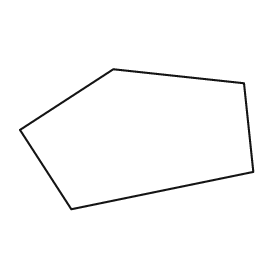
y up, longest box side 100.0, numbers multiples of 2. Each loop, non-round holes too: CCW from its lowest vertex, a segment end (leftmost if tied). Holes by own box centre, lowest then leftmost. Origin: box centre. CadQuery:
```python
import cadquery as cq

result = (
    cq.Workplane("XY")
    .moveTo(-28.0, -30.0)
    .lineTo(50.0, -14.0)
    .lineTo(46.0, 24.0)
    .lineTo(-10.0, 30.0)
    .lineTo(-50.0, 4.0)
    .close()
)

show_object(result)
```